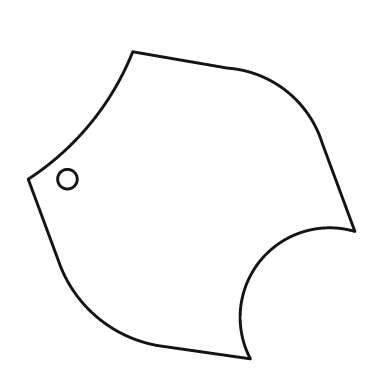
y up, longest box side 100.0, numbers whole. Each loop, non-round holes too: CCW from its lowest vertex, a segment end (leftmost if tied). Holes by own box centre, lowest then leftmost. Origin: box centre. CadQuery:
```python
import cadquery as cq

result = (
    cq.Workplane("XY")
    .moveTo(18.0, -47.0)
    .threePointArc((21.0, -17.0), (50.0, -8.0))
    .lineTo(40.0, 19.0)
    .threePointArc((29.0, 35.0), (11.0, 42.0))
    .lineTo(-18.0, 47.0)
    .threePointArc((-31.0, 25.0), (-50.0, 8.0))
    .lineTo(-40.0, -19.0)
    .threePointArc((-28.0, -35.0), (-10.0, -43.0))
    .close()
    .moveTo(-38.0, 8.0)
    .circle(3.0)
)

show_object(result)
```